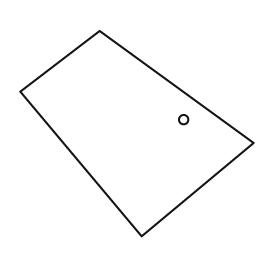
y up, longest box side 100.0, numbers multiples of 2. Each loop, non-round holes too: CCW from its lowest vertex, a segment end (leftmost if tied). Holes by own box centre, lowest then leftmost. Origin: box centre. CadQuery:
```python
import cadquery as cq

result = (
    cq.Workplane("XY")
    .moveTo(2.0, -44.0)
    .lineTo(50.0, -4.0)
    .lineTo(-16.0, 44.0)
    .lineTo(-50.0, 18.0)
    .close()
    .moveTo(20.0, 6.0)
    .circle(2.0)
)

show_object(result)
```